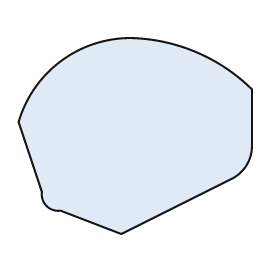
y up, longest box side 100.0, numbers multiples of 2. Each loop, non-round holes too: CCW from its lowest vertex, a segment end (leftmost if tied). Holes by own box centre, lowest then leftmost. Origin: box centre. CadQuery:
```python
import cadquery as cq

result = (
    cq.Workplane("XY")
    .moveTo(-6.0, -42.0)
    .lineTo(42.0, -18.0)
    .threePointArc((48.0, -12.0), (50.0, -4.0))
    .lineTo(50.0, 20.0)
    .threePointArc((26.0, 36.0), (-2.0, 42.0))
    .threePointArc((-32.0, 32.0), (-50.0, 6.0))
    .lineTo(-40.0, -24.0)
    .threePointArc((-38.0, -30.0), (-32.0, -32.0))
    .close()
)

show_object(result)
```